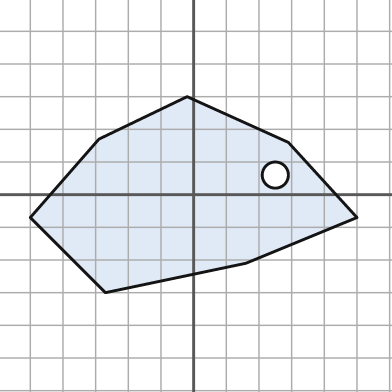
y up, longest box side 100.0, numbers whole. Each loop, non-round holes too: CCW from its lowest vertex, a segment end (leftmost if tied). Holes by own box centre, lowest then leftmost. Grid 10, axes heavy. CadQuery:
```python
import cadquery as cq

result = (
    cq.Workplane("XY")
    .moveTo(-27.0, -30.0)
    .lineTo(16.0, -21.0)
    .lineTo(50.0, -7.0)
    .lineTo(29.0, 16.0)
    .lineTo(-2.0, 30.0)
    .lineTo(-29.0, 17.0)
    .lineTo(-50.0, -7.0)
    .close()
    .moveTo(25.0, 6.0)
    .circle(4.0)
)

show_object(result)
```